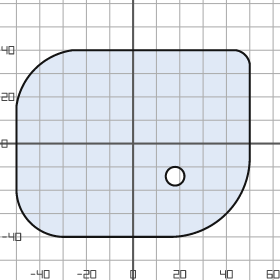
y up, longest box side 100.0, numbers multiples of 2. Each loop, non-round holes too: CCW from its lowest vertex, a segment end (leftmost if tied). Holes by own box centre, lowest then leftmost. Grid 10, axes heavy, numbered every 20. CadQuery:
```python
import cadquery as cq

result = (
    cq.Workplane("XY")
    .moveTo(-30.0, -40.0)
    .lineTo(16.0, -40.0)
    .threePointArc((40.0, -30.0), (50.0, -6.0))
    .lineTo(50.0, 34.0)
    .threePointArc((48.0, 38.0), (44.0, 40.0))
    .lineTo(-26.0, 40.0)
    .threePointArc((-42.0, 32.0), (-50.0, 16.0))
    .lineTo(-50.0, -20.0)
    .threePointArc((-44.0, -34.0), (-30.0, -40.0))
    .close()
    .moveTo(18.0, -14.0)
    .circle(4.0)
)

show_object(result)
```